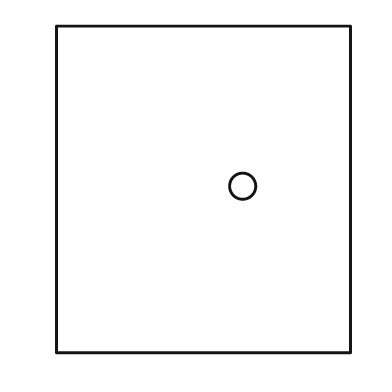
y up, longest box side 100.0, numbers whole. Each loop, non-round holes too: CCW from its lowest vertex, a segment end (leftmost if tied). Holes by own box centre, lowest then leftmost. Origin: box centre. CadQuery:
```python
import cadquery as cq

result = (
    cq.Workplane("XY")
    .moveTo(-45.0, -50.0)
    .lineTo(45.0, -50.0)
    .lineTo(45.0, 50.0)
    .lineTo(-45.0, 50.0)
    .close()
    .moveTo(12.0, 1.0)
    .circle(4.0)
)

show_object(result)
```